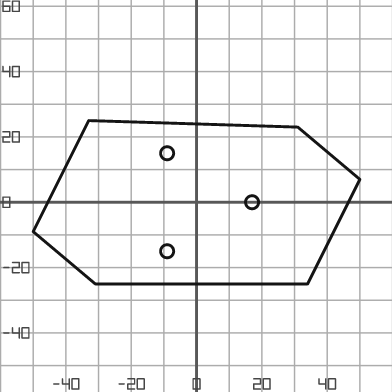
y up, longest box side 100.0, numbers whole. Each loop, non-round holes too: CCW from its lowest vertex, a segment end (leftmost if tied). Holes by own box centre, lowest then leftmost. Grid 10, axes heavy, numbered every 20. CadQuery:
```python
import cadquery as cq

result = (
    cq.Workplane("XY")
    .moveTo(-31.0, -25.0)
    .lineTo(34.0, -25.0)
    .lineTo(50.0, 7.0)
    .lineTo(31.0, 23.0)
    .lineTo(-33.0, 25.0)
    .lineTo(-50.0, -9.0)
    .close()
    .moveTo(-9.0, -15.0)
    .circle(2.0)
    .moveTo(17.0, 0.0)
    .circle(2.0)
    .moveTo(-9.0, 15.0)
    .circle(2.0)
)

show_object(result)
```